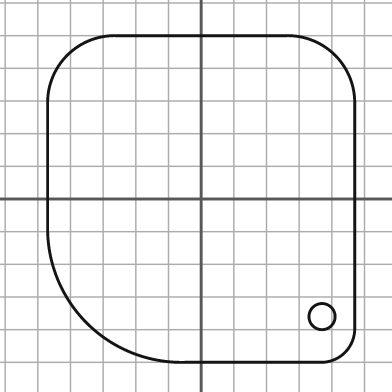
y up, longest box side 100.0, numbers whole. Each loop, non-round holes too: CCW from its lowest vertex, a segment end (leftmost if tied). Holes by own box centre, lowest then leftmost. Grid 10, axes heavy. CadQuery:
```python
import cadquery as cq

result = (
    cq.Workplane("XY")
    .moveTo(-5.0, -50.0)
    .lineTo(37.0, -50.0)
    .threePointArc((44.0, -47.0), (47.0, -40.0))
    .lineTo(47.0, 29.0)
    .threePointArc((41.0, 44.0), (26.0, 50.0))
    .lineTo(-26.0, 50.0)
    .threePointArc((-41.0, 44.0), (-47.0, 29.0))
    .lineTo(-47.0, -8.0)
    .threePointArc((-35.0, -38.0), (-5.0, -50.0))
    .close()
    .moveTo(37.0, -36.0)
    .circle(4.0)
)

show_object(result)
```